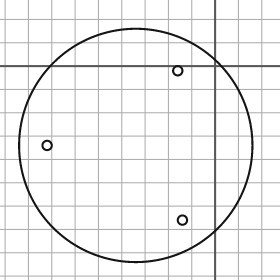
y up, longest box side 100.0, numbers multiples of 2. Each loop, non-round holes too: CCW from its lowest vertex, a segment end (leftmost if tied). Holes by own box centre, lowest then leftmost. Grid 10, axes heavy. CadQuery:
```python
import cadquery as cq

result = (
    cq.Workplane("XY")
    .moveTo(-34.0, -34.0)
    .circle(50.0)
    .moveTo(-14.0, -66.0)
    .circle(2.0)
    .moveTo(-72.0, -34.0)
    .circle(2.0)
    .moveTo(-16.0, -2.0)
    .circle(2.0)
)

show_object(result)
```